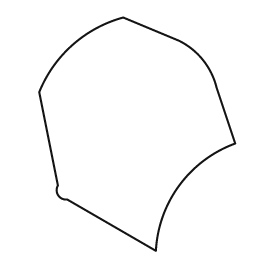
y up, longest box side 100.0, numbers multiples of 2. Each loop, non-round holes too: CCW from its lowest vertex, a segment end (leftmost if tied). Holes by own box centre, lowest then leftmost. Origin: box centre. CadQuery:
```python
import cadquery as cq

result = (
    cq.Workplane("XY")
    .moveTo(8.0, -50.0)
    .threePointArc((18.0, -22.0), (42.0, -4.0))
    .lineTo(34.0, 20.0)
    .threePointArc((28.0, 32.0), (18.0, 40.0))
    .lineTo(-6.0, 50.0)
    .threePointArc((-28.0, 38.0), (-42.0, 18.0))
    .lineTo(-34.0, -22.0)
    .threePointArc((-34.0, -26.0), (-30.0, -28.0))
    .close()
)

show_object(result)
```